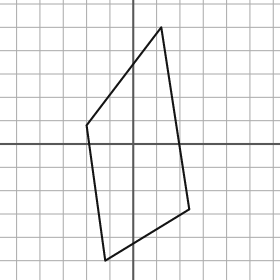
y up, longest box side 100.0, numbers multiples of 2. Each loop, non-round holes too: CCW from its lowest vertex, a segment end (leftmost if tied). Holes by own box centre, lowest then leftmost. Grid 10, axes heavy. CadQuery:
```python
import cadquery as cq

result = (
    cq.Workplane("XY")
    .moveTo(-12.0, -50.0)
    .lineTo(24.0, -28.0)
    .lineTo(12.0, 50.0)
    .lineTo(-20.0, 8.0)
    .close()
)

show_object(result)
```